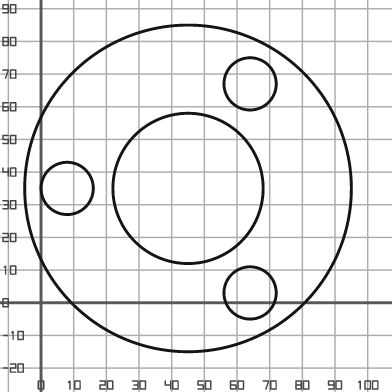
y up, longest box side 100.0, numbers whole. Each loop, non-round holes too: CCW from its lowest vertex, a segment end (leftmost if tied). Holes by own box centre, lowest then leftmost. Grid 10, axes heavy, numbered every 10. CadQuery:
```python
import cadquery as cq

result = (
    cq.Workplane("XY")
    .moveTo(45.0, 35.0)
    .circle(50.0)
    .moveTo(64.0, 3.0)
    .circle(8.0)
    .moveTo(8.0, 35.0)
    .circle(8.0)
    .moveTo(45.0, 35.0)
    .circle(23.0)
    .moveTo(64.0, 67.0)
    .circle(8.0)
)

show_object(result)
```